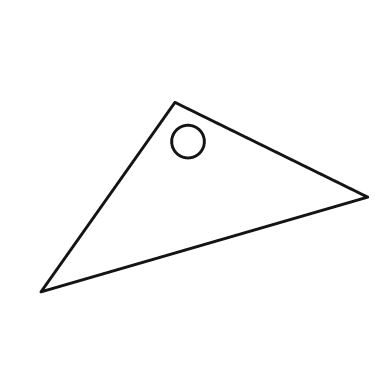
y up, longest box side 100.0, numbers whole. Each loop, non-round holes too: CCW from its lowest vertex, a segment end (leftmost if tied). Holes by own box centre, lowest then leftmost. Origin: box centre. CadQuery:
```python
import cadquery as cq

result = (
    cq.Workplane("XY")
    .moveTo(-50.0, -29.0)
    .lineTo(50.0, 0.0)
    .lineTo(-9.0, 29.0)
    .close()
    .moveTo(-5.0, 17.0)
    .circle(5.0)
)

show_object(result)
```